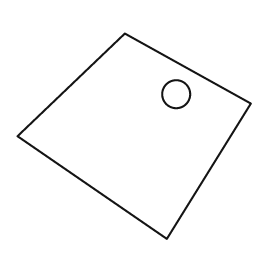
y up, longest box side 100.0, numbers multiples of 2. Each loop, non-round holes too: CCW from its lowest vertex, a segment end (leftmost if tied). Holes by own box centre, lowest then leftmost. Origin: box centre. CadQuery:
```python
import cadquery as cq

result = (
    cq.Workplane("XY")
    .moveTo(14.0, -44.0)
    .lineTo(50.0, 14.0)
    .lineTo(-4.0, 44.0)
    .lineTo(-50.0, 0.0)
    .close()
    .moveTo(18.0, 18.0)
    .circle(6.0)
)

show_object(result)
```